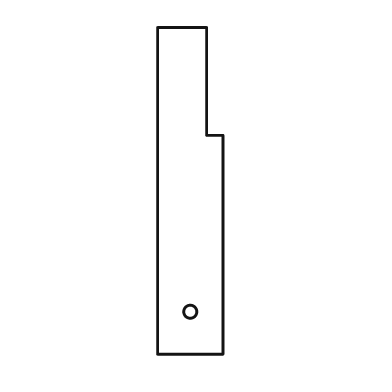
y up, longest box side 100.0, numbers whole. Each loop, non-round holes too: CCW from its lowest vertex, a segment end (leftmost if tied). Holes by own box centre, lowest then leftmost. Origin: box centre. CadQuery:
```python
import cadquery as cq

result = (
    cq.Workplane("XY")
    .moveTo(-10.0, -50.0)
    .lineTo(10.0, -50.0)
    .lineTo(10.0, 17.0)
    .lineTo(5.0, 17.0)
    .lineTo(5.0, 50.0)
    .lineTo(-10.0, 50.0)
    .close()
    .moveTo(0.0, -37.0)
    .circle(2.0)
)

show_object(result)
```